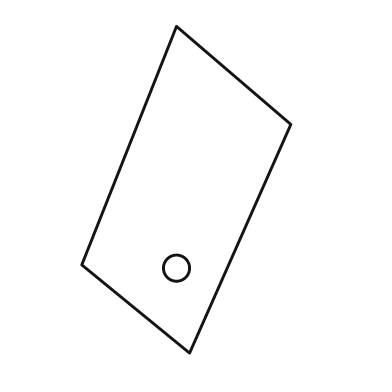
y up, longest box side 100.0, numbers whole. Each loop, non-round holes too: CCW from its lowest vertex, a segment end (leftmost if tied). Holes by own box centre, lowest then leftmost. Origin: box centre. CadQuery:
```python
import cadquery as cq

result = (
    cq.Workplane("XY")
    .moveTo(1.0, -50.0)
    .lineTo(32.0, 20.0)
    .lineTo(-3.0, 50.0)
    .lineTo(-32.0, -23.0)
    .close()
    .moveTo(-3.0, -24.0)
    .circle(4.0)
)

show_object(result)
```